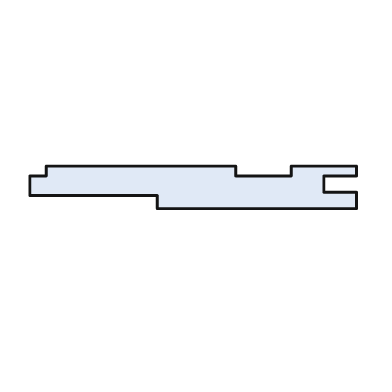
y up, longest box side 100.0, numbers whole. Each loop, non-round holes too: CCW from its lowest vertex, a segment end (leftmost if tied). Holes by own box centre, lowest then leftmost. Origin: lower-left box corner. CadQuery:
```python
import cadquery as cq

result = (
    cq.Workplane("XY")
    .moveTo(39.0, 0.0)
    .lineTo(100.0, 0.0)
    .lineTo(100.0, 5.0)
    .lineTo(90.0, 5.0)
    .lineTo(90.0, 10.0)
    .lineTo(100.0, 10.0)
    .lineTo(100.0, 13.0)
    .lineTo(80.0, 13.0)
    .lineTo(80.0, 10.0)
    .lineTo(63.0, 10.0)
    .lineTo(63.0, 13.0)
    .lineTo(5.0, 13.0)
    .lineTo(5.0, 10.0)
    .lineTo(0.0, 10.0)
    .lineTo(0.0, 4.0)
    .lineTo(39.0, 4.0)
    .close()
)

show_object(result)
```